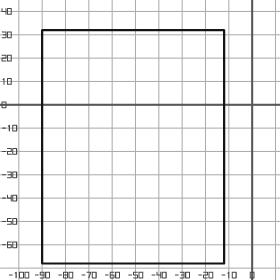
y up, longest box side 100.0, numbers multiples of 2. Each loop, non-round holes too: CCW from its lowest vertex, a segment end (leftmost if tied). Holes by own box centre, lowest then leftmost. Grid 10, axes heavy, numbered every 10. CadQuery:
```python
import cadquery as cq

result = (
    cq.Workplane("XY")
    .moveTo(-90.0, -68.0)
    .lineTo(-12.0, -68.0)
    .lineTo(-12.0, 32.0)
    .lineTo(-90.0, 32.0)
    .close()
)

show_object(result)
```